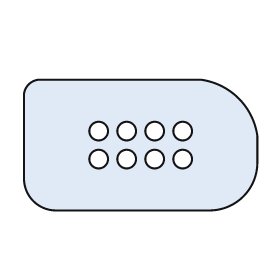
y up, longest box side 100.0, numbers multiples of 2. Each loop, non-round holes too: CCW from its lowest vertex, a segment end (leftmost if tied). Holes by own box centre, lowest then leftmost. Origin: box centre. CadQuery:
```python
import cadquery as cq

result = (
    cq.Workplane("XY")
    .moveTo(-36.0, -28.0)
    .lineTo(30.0, -28.0)
    .threePointArc((44.0, -22.0), (50.0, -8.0))
    .lineTo(50.0, 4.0)
    .threePointArc((42.0, 20.0), (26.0, 28.0))
    .lineTo(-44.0, 28.0)
    .threePointArc((-48.0, 26.0), (-50.0, 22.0))
    .lineTo(-50.0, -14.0)
    .threePointArc((-46.0, -24.0), (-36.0, -28.0))
    .close()
    .moveTo(-18.0, -6.0)
    .circle(4.0)
    .moveTo(-6.0, -6.0)
    .circle(4.0)
    .moveTo(6.0, -6.0)
    .circle(4.0)
    .moveTo(18.0, -6.0)
    .circle(4.0)
    .moveTo(-18.0, 6.0)
    .circle(4.0)
    .moveTo(-6.0, 6.0)
    .circle(4.0)
    .moveTo(6.0, 6.0)
    .circle(4.0)
    .moveTo(18.0, 6.0)
    .circle(4.0)
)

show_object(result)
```